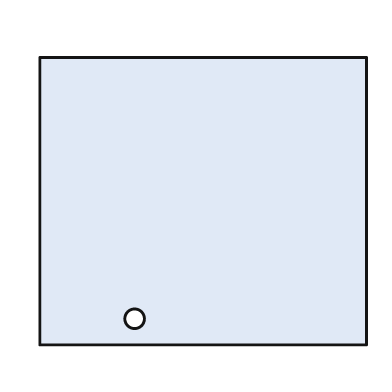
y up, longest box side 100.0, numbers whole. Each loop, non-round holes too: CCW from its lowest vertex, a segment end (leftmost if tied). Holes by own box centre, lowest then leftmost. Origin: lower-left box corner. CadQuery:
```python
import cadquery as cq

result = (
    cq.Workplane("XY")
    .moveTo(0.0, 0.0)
    .lineTo(100.0, 0.0)
    .lineTo(100.0, 88.0)
    .lineTo(0.0, 88.0)
    .close()
    .moveTo(29.0, 8.0)
    .circle(3.0)
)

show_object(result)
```